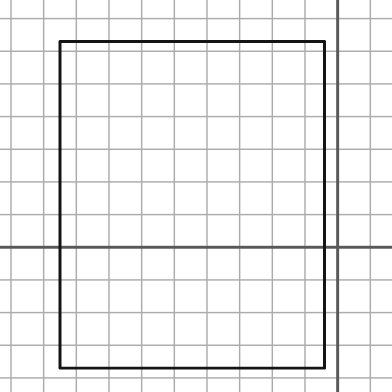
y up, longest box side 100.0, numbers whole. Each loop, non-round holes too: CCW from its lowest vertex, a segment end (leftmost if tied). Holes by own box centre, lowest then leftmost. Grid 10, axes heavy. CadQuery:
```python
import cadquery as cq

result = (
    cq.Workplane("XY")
    .moveTo(-85.0, -37.0)
    .lineTo(-4.0, -37.0)
    .lineTo(-4.0, 63.0)
    .lineTo(-85.0, 63.0)
    .close()
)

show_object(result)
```